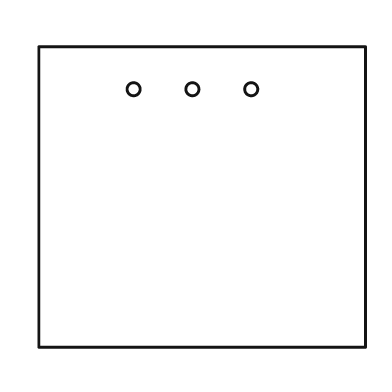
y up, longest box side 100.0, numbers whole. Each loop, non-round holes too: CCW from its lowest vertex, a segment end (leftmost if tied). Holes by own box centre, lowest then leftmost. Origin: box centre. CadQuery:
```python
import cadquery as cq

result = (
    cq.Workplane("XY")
    .moveTo(-50.0, -46.0)
    .lineTo(50.0, -46.0)
    .lineTo(50.0, 46.0)
    .lineTo(-50.0, 46.0)
    .close()
    .moveTo(-21.0, 33.0)
    .circle(2.0)
    .moveTo(-3.0, 33.0)
    .circle(2.0)
    .moveTo(15.0, 33.0)
    .circle(2.0)
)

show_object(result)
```